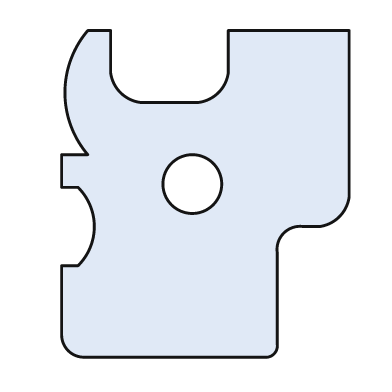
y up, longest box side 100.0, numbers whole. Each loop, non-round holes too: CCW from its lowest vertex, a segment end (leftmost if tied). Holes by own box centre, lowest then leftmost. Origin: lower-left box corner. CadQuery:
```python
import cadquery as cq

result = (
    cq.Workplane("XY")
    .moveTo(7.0, 0.0)
    .lineTo(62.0, 0.0)
    .threePointArc((65.0, 1.0), (66.0, 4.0))
    .lineTo(66.0, 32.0)
    .threePointArc((68.0, 38.0), (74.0, 40.0))
    .lineTo(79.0, 40.0)
    .threePointArc((85.0, 43.0), (88.0, 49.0))
    .lineTo(88.0, 100.0)
    .lineTo(51.0, 100.0)
    .lineTo(51.0, 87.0)
    .threePointArc((48.0, 81.0), (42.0, 78.0))
    .lineTo(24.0, 78.0)
    .threePointArc((18.0, 81.0), (15.0, 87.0))
    .lineTo(15.0, 100.0)
    .lineTo(8.0, 100.0)
    .threePointArc((1.0, 81.0), (8.0, 62.0))
    .lineTo(0.0, 62.0)
    .lineTo(0.0, 52.0)
    .lineTo(5.0, 52.0)
    .threePointArc((10.0, 40.0), (5.0, 28.0))
    .lineTo(0.0, 28.0)
    .lineTo(0.0, 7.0)
    .threePointArc((2.0, 2.0), (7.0, 0.0))
    .close()
    .moveTo(40.0, 53.0)
    .circle(9.0)
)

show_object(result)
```